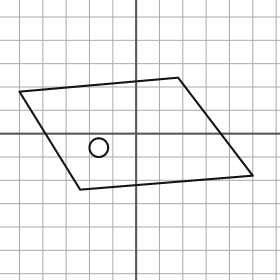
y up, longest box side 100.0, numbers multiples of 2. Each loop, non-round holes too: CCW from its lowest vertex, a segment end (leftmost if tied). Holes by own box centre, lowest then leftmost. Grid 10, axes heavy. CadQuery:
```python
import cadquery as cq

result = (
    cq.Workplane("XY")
    .moveTo(-24.0, -24.0)
    .lineTo(50.0, -18.0)
    .lineTo(18.0, 24.0)
    .lineTo(-50.0, 18.0)
    .close()
    .moveTo(-16.0, -6.0)
    .circle(4.0)
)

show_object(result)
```